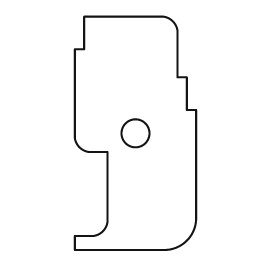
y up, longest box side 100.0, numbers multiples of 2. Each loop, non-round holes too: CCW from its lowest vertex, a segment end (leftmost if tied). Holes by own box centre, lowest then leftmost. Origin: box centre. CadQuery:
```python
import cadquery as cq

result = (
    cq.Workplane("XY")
    .moveTo(-26.0, -50.0)
    .lineTo(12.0, -50.0)
    .threePointArc((22.0, -46.0), (26.0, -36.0))
    .lineTo(26.0, 10.0)
    .lineTo(22.0, 10.0)
    .lineTo(22.0, 24.0)
    .lineTo(18.0, 24.0)
    .lineTo(18.0, 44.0)
    .threePointArc((16.0, 48.0), (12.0, 50.0))
    .lineTo(-22.0, 50.0)
    .lineTo(-22.0, 36.0)
    .lineTo(-26.0, 36.0)
    .lineTo(-26.0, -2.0)
    .threePointArc((-24.0, -6.0), (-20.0, -8.0))
    .lineTo(-12.0, -8.0)
    .lineTo(-12.0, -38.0)
    .threePointArc((-14.0, -42.0), (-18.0, -44.0))
    .lineTo(-26.0, -44.0)
    .close()
    .moveTo(0.0, 0.0)
    .circle(6.0)
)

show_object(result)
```